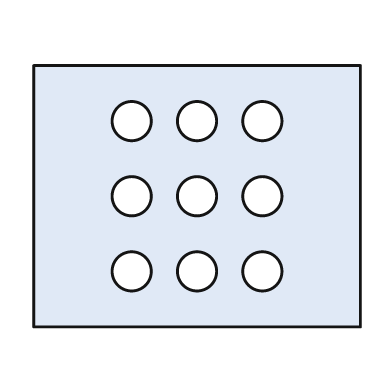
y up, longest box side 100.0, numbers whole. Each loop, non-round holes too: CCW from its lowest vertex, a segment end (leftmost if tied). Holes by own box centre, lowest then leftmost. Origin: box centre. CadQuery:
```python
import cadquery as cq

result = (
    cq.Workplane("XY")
    .moveTo(-50.0, -40.0)
    .lineTo(50.0, -40.0)
    .lineTo(50.0, 40.0)
    .lineTo(-50.0, 40.0)
    .close()
    .moveTo(-20.0, -23.0)
    .circle(6.0)
    .moveTo(0.0, -23.0)
    .circle(6.0)
    .moveTo(20.0, -23.0)
    .circle(6.0)
    .moveTo(-20.0, 0.0)
    .circle(6.0)
    .moveTo(0.0, 0.0)
    .circle(6.0)
    .moveTo(20.0, 0.0)
    .circle(6.0)
    .moveTo(-20.0, 23.0)
    .circle(6.0)
    .moveTo(0.0, 23.0)
    .circle(6.0)
    .moveTo(20.0, 23.0)
    .circle(6.0)
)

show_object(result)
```